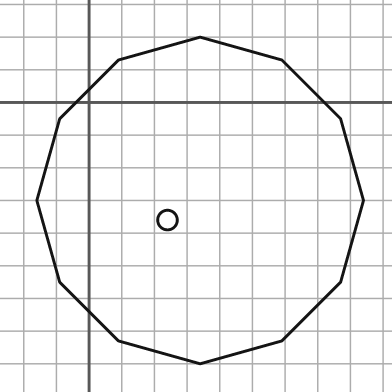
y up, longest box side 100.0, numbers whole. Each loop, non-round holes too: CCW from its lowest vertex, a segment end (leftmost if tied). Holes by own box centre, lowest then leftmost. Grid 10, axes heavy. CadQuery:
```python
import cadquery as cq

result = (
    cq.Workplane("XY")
    .moveTo(34.0, -80.0)
    .lineTo(59.0, -73.0)
    .lineTo(77.0, -55.0)
    .lineTo(84.0, -30.0)
    .lineTo(77.0, -5.0)
    .lineTo(59.0, 13.0)
    .lineTo(34.0, 20.0)
    .lineTo(9.0, 13.0)
    .lineTo(-9.0, -5.0)
    .lineTo(-16.0, -30.0)
    .lineTo(-9.0, -55.0)
    .lineTo(9.0, -73.0)
    .close()
    .moveTo(24.0, -36.0)
    .circle(3.0)
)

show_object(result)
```